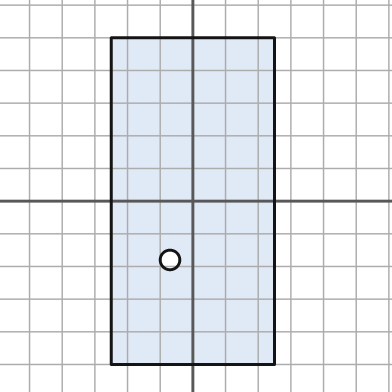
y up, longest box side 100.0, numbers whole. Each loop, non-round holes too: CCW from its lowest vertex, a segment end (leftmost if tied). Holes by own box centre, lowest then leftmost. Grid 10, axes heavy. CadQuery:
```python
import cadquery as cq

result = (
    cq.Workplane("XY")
    .moveTo(-25.0, -50.0)
    .lineTo(25.0, -50.0)
    .lineTo(25.0, 50.0)
    .lineTo(-25.0, 50.0)
    .close()
    .moveTo(-7.0, -18.0)
    .circle(3.0)
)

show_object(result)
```